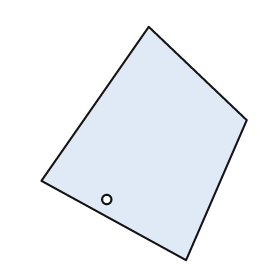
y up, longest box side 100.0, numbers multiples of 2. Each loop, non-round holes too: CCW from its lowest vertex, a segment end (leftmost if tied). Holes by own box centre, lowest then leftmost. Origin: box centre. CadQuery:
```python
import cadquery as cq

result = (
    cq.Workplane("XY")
    .moveTo(18.0, -50.0)
    .lineTo(44.0, 10.0)
    .lineTo(2.0, 50.0)
    .lineTo(-44.0, -16.0)
    .close()
    .moveTo(-16.0, -24.0)
    .circle(2.0)
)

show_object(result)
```